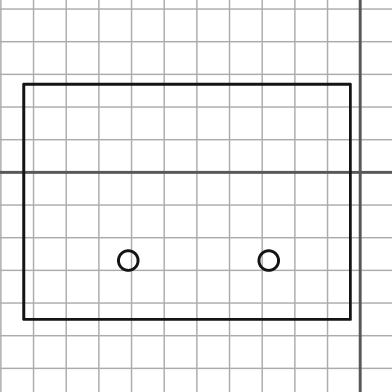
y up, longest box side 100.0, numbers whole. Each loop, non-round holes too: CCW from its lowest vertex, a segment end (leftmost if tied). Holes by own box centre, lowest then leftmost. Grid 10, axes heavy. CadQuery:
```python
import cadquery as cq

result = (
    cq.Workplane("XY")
    .moveTo(-103.0, -45.0)
    .lineTo(-3.0, -45.0)
    .lineTo(-3.0, 27.0)
    .lineTo(-103.0, 27.0)
    .close()
    .moveTo(-71.0, -27.0)
    .circle(3.0)
    .moveTo(-28.0, -27.0)
    .circle(3.0)
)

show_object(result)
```